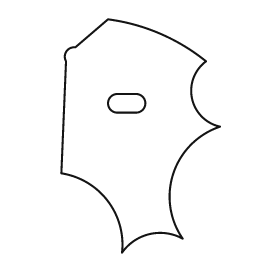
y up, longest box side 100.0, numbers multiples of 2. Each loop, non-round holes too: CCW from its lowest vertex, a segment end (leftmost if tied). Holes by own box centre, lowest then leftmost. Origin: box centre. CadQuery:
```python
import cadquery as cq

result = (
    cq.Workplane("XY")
    .moveTo(-8.0, -50.0)
    .threePointArc((4.0, -42.0), (18.0, -44.0))
    .threePointArc((14.0, -16.0), (34.0, 4.0))
    .threePointArc((22.0, 16.0), (28.0, 32.0))
    .threePointArc((8.0, 44.0), (-14.0, 50.0))
    .lineTo(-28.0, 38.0)
    .threePointArc((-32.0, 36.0), (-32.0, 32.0))
    .lineTo(-34.0, -16.0)
    .threePointArc((-14.0, -28.0), (-8.0, -50.0))
    .close()
    .moveTo(-10.0, 10.0)
    .lineTo(-2.0, 10.0)
    .threePointArc((2.0, 14.0), (-2.0, 18.0))
    .lineTo(-10.0, 18.0)
    .threePointArc((-14.0, 14.0), (-10.0, 10.0))
    .close()
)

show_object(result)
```